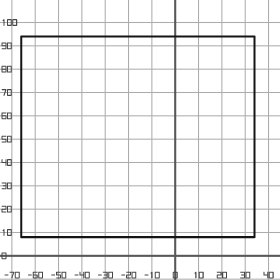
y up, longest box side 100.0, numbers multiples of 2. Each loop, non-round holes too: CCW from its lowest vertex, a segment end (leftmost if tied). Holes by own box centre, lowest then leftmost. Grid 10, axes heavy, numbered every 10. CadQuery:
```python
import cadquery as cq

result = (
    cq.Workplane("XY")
    .moveTo(-66.0, 8.0)
    .lineTo(34.0, 8.0)
    .lineTo(34.0, 94.0)
    .lineTo(-66.0, 94.0)
    .close()
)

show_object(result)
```